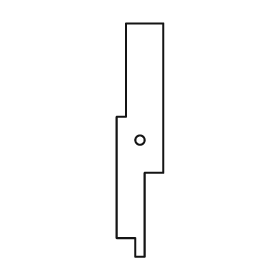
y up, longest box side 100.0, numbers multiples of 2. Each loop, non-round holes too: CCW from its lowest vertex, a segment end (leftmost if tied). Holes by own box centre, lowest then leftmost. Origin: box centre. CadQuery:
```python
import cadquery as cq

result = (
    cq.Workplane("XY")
    .moveTo(-2.0, -50.0)
    .lineTo(2.0, -50.0)
    .lineTo(2.0, -14.0)
    .lineTo(10.0, -14.0)
    .lineTo(10.0, 50.0)
    .lineTo(-6.0, 50.0)
    .lineTo(-6.0, 10.0)
    .lineTo(-10.0, 10.0)
    .lineTo(-10.0, -42.0)
    .lineTo(-2.0, -42.0)
    .close()
    .moveTo(0.0, 0.0)
    .circle(2.0)
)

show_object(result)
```